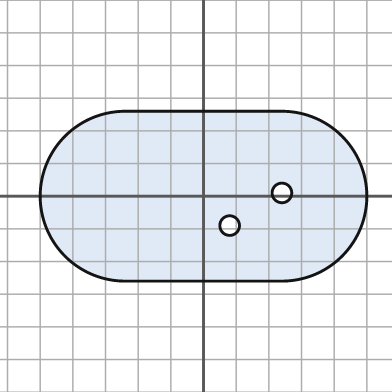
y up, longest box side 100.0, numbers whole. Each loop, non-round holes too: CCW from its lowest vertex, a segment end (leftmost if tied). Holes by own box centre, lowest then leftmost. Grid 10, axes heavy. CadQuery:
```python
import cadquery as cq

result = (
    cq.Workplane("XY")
    .moveTo(-24.0, -26.0)
    .lineTo(24.0, -26.0)
    .threePointArc((50.0, 0.0), (24.0, 26.0))
    .lineTo(-24.0, 26.0)
    .threePointArc((-50.0, 0.0), (-24.0, -26.0))
    .close()
    .moveTo(8.0, -9.0)
    .circle(3.0)
    .moveTo(24.0, 1.0)
    .circle(3.0)
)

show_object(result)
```